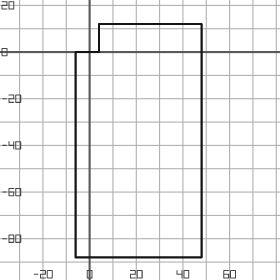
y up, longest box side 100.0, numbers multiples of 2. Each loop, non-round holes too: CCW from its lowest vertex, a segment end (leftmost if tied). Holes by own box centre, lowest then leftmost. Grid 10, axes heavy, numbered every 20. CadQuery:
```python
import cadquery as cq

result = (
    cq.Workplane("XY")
    .moveTo(-6.0, -88.0)
    .lineTo(48.0, -88.0)
    .lineTo(48.0, 12.0)
    .lineTo(4.0, 12.0)
    .lineTo(4.0, 0.0)
    .lineTo(-6.0, 0.0)
    .close()
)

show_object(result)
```